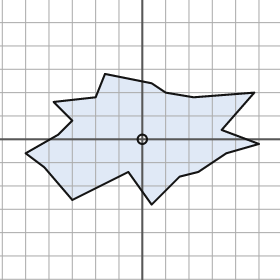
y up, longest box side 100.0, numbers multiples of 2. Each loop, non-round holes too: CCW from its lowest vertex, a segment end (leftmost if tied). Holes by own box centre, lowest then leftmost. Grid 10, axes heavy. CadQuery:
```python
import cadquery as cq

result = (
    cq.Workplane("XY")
    .moveTo(4.0, -28.0)
    .lineTo(16.0, -16.0)
    .lineTo(24.0, -14.0)
    .lineTo(36.0, -6.0)
    .lineTo(50.0, -2.0)
    .lineTo(34.0, 4.0)
    .lineTo(48.0, 20.0)
    .lineTo(22.0, 18.0)
    .lineTo(10.0, 20.0)
    .lineTo(4.0, 24.0)
    .lineTo(-16.0, 28.0)
    .lineTo(-20.0, 18.0)
    .lineTo(-38.0, 16.0)
    .lineTo(-30.0, 8.0)
    .lineTo(-36.0, 2.0)
    .lineTo(-50.0, -6.0)
    .lineTo(-42.0, -12.0)
    .lineTo(-30.0, -26.0)
    .lineTo(-6.0, -14.0)
    .close()
    .moveTo(0.0, 0.0)
    .circle(2.0)
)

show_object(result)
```